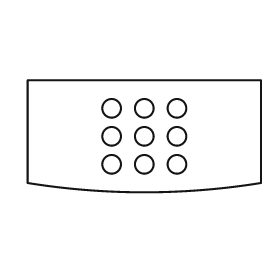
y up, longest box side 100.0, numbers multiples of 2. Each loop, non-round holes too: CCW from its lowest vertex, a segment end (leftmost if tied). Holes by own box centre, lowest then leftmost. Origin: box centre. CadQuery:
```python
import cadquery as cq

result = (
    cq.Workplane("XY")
    .moveTo(-50.0, -20.0)
    .threePointArc((0.0, -24.0), (50.0, -20.0))
    .lineTo(50.0, 24.0)
    .lineTo(-50.0, 24.0)
    .close()
    .moveTo(-14.0, -12.0)
    .circle(4.0)
    .moveTo(0.0, -12.0)
    .circle(4.0)
    .moveTo(14.0, -12.0)
    .circle(4.0)
    .moveTo(-14.0, 0.0)
    .circle(4.0)
    .moveTo(0.0, 0.0)
    .circle(4.0)
    .moveTo(14.0, 0.0)
    .circle(4.0)
    .moveTo(-14.0, 12.0)
    .circle(4.0)
    .moveTo(0.0, 12.0)
    .circle(4.0)
    .moveTo(14.0, 12.0)
    .circle(4.0)
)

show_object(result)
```